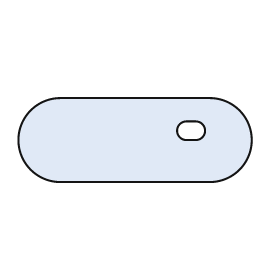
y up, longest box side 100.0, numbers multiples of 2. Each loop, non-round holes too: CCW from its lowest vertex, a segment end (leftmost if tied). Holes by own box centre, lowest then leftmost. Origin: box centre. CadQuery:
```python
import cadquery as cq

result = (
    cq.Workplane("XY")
    .moveTo(-32.0, -18.0)
    .lineTo(32.0, -18.0)
    .threePointArc((50.0, 0.0), (32.0, 18.0))
    .lineTo(-32.0, 18.0)
    .threePointArc((-50.0, 0.0), (-32.0, -18.0))
    .close()
    .moveTo(22.0, 0.0)
    .lineTo(26.0, 0.0)
    .threePointArc((30.0, 4.0), (26.0, 8.0))
    .lineTo(22.0, 8.0)
    .threePointArc((18.0, 4.0), (22.0, 0.0))
    .close()
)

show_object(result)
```